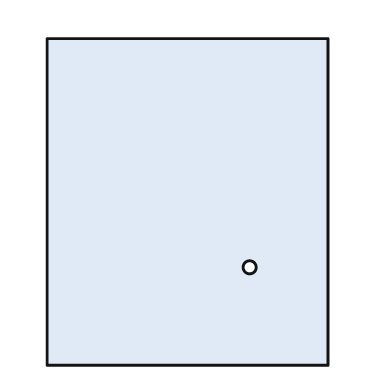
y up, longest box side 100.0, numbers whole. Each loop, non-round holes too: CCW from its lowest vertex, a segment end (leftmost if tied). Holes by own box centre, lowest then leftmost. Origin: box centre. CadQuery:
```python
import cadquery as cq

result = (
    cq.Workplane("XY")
    .moveTo(-43.0, -50.0)
    .lineTo(43.0, -50.0)
    .lineTo(43.0, 50.0)
    .lineTo(-43.0, 50.0)
    .close()
    .moveTo(19.0, -20.0)
    .circle(2.0)
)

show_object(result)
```